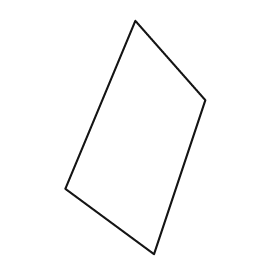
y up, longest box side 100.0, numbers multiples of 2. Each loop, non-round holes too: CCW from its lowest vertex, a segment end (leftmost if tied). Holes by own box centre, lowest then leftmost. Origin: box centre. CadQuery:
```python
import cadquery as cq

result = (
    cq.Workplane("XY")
    .moveTo(8.0, -50.0)
    .lineTo(30.0, 16.0)
    .lineTo(0.0, 50.0)
    .lineTo(-30.0, -22.0)
    .close()
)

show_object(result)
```